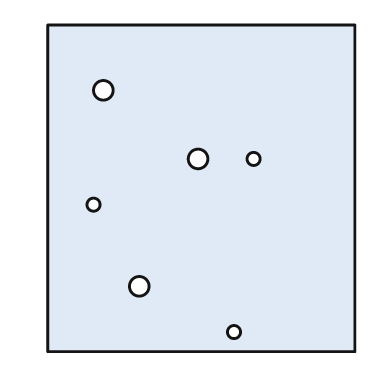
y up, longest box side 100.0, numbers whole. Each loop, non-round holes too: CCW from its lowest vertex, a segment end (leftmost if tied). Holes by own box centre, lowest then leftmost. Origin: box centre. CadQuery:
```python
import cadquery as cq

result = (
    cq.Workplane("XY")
    .moveTo(-47.0, -50.0)
    .lineTo(47.0, -50.0)
    .lineTo(47.0, 50.0)
    .lineTo(-47.0, 50.0)
    .close()
    .moveTo(10.0, -44.0)
    .circle(2.0)
    .moveTo(-19.0, -30.0)
    .circle(3.0)
    .moveTo(-33.0, -5.0)
    .circle(2.0)
    .moveTo(-1.0, 9.0)
    .circle(3.0)
    .moveTo(16.0, 9.0)
    .circle(2.0)
    .moveTo(-30.0, 30.0)
    .circle(3.0)
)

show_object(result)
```